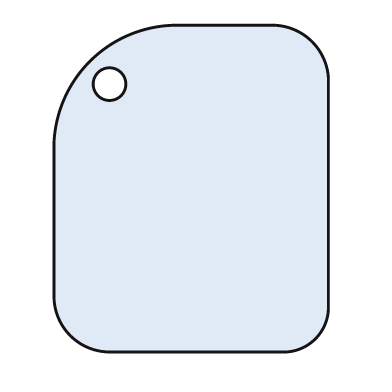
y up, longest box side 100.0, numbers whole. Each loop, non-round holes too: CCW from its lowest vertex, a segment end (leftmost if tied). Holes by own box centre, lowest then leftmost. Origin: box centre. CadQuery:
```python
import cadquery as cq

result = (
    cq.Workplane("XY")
    .moveTo(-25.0, -50.0)
    .lineTo(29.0, -50.0)
    .threePointArc((38.0, -46.0), (42.0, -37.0))
    .lineTo(42.0, 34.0)
    .threePointArc((37.0, 45.0), (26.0, 50.0))
    .lineTo(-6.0, 50.0)
    .threePointArc((-31.0, 39.0), (-42.0, 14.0))
    .lineTo(-42.0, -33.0)
    .threePointArc((-37.0, -45.0), (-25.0, -50.0))
    .close()
    .moveTo(-25.0, 32.0)
    .circle(5.0)
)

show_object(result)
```